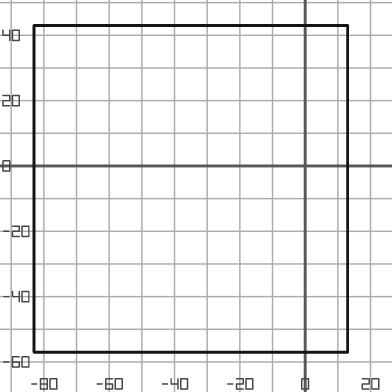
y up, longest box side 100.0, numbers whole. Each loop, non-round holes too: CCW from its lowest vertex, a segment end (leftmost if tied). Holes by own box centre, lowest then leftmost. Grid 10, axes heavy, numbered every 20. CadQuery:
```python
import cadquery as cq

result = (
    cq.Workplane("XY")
    .moveTo(-83.0, -57.0)
    .lineTo(13.0, -57.0)
    .lineTo(13.0, 43.0)
    .lineTo(-83.0, 43.0)
    .close()
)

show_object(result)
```